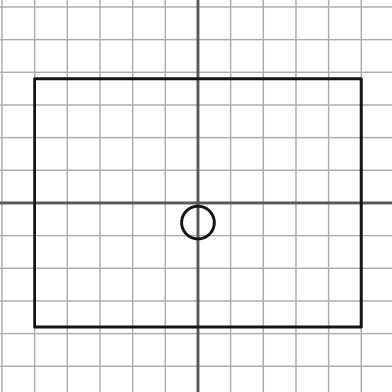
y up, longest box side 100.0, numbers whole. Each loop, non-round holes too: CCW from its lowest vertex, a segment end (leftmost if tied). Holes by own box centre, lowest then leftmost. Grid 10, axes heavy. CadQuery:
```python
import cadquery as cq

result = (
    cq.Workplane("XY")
    .moveTo(-50.0, -38.0)
    .lineTo(50.0, -38.0)
    .lineTo(50.0, 38.0)
    .lineTo(-50.0, 38.0)
    .close()
    .moveTo(0.0, -6.0)
    .circle(5.0)
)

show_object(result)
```